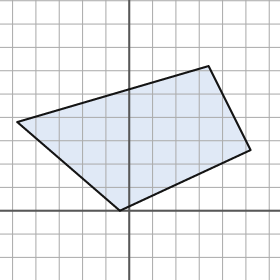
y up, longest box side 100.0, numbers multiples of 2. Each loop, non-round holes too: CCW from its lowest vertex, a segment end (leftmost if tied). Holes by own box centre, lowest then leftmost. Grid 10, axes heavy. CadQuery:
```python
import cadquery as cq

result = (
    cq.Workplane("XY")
    .moveTo(-4.0, 0.0)
    .lineTo(52.0, 26.0)
    .lineTo(34.0, 62.0)
    .lineTo(-48.0, 38.0)
    .close()
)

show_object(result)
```